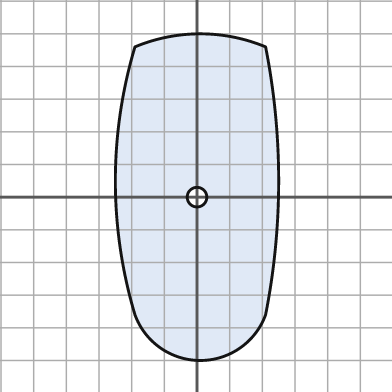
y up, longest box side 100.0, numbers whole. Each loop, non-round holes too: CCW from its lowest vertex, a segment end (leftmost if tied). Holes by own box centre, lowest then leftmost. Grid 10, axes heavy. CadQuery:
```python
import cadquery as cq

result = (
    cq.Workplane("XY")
    .moveTo(-19.0, -36.0)
    .threePointArc((1.0, -50.0), (21.0, -36.0))
    .threePointArc((25.0, 5.0), (21.0, 46.0))
    .threePointArc((1.0, 50.0), (-19.0, 46.0))
    .threePointArc((-25.0, 5.0), (-19.0, -36.0))
    .close()
    .moveTo(0.0, 0.0)
    .circle(3.0)
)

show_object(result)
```